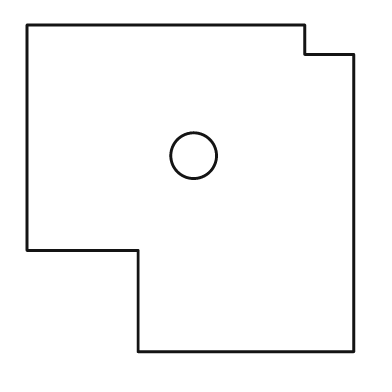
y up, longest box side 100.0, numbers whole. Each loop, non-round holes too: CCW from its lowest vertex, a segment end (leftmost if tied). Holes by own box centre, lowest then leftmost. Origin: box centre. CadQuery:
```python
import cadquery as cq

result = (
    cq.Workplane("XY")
    .moveTo(-16.0, -50.0)
    .lineTo(50.0, -50.0)
    .lineTo(50.0, 41.0)
    .lineTo(35.0, 41.0)
    .lineTo(35.0, 50.0)
    .lineTo(-50.0, 50.0)
    .lineTo(-50.0, -19.0)
    .lineTo(-16.0, -19.0)
    .close()
    .moveTo(1.0, 10.0)
    .circle(7.0)
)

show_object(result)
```